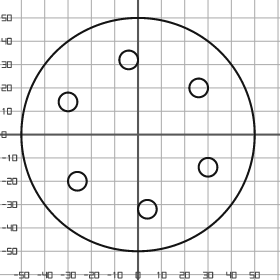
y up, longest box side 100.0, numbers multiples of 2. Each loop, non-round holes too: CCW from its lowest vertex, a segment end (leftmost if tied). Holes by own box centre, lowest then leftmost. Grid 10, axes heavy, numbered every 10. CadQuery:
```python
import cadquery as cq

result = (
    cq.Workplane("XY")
    .moveTo(0.0, 0.0)
    .circle(50.0)
    .moveTo(4.0, -32.0)
    .circle(4.0)
    .moveTo(-26.0, -20.0)
    .circle(4.0)
    .moveTo(30.0, -14.0)
    .circle(4.0)
    .moveTo(-30.0, 14.0)
    .circle(4.0)
    .moveTo(26.0, 20.0)
    .circle(4.0)
    .moveTo(-4.0, 32.0)
    .circle(4.0)
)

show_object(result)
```